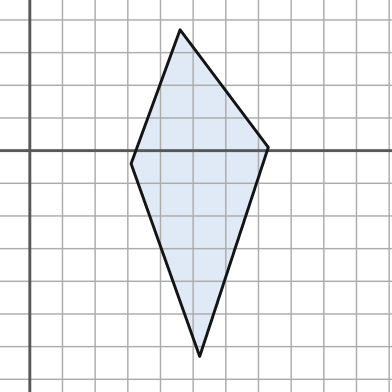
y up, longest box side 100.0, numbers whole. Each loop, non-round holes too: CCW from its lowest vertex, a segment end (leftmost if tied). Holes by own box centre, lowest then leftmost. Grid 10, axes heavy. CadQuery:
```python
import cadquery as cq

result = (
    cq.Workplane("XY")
    .moveTo(52.0, -63.0)
    .lineTo(73.0, 1.0)
    .lineTo(46.0, 37.0)
    .lineTo(31.0, -4.0)
    .close()
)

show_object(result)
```